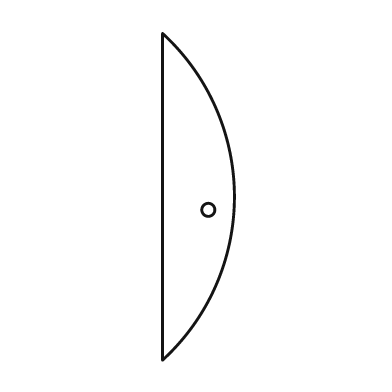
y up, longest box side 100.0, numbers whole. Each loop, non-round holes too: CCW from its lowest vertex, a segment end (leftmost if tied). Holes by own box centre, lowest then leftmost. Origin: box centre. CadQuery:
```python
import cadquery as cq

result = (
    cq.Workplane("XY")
    .moveTo(-11.0, -50.0)
    .threePointArc((11.0, 0.0), (-11.0, 50.0))
    .close()
    .moveTo(3.0, -4.0)
    .circle(2.0)
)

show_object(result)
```